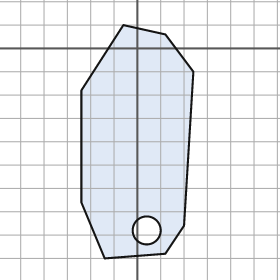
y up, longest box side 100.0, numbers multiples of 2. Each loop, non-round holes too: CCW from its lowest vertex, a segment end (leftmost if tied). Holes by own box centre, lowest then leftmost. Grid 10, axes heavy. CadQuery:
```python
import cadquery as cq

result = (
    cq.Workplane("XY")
    .moveTo(-14.0, -90.0)
    .lineTo(12.0, -88.0)
    .lineTo(20.0, -76.0)
    .lineTo(24.0, -10.0)
    .lineTo(12.0, 6.0)
    .lineTo(-6.0, 10.0)
    .lineTo(-24.0, -18.0)
    .lineTo(-24.0, -66.0)
    .close()
    .moveTo(4.0, -78.0)
    .circle(6.0)
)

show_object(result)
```